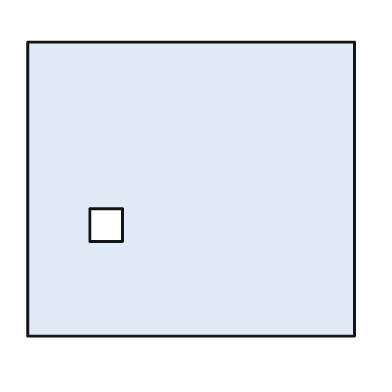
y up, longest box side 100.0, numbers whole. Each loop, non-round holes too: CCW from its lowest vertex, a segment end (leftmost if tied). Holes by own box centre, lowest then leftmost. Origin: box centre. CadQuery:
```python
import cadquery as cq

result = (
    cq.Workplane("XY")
    .moveTo(-50.0, -45.0)
    .lineTo(50.0, -45.0)
    .lineTo(50.0, 45.0)
    .lineTo(-50.0, 45.0)
    .close()
    .moveTo(-31.0, -16.0)
    .lineTo(-21.0, -16.0)
    .lineTo(-21.0, -6.0)
    .lineTo(-31.0, -6.0)
    .close()
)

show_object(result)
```